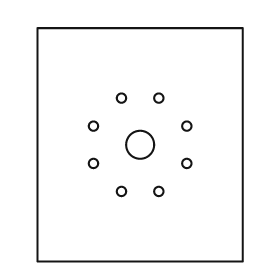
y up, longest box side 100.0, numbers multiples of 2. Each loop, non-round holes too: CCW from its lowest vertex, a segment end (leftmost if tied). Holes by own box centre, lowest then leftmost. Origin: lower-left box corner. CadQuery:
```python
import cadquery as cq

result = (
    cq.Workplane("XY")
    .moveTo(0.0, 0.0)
    .lineTo(88.0, 0.0)
    .lineTo(88.0, 100.0)
    .lineTo(0.0, 100.0)
    .close()
    .moveTo(36.0, 30.0)
    .circle(2.0)
    .moveTo(52.0, 30.0)
    .circle(2.0)
    .moveTo(24.0, 42.0)
    .circle(2.0)
    .moveTo(64.0, 42.0)
    .circle(2.0)
    .moveTo(44.0, 50.0)
    .circle(6.0)
    .moveTo(24.0, 58.0)
    .circle(2.0)
    .moveTo(64.0, 58.0)
    .circle(2.0)
    .moveTo(36.0, 70.0)
    .circle(2.0)
    .moveTo(52.0, 70.0)
    .circle(2.0)
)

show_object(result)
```